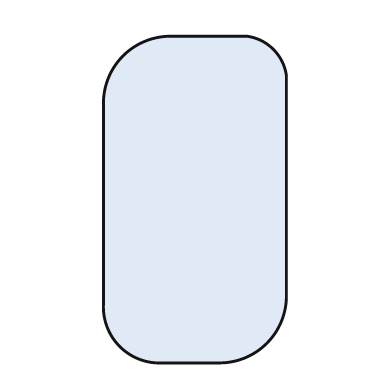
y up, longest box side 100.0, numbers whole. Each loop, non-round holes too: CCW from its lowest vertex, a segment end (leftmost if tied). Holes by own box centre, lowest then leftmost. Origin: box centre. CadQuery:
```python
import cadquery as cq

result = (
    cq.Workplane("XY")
    .moveTo(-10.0, -50.0)
    .lineTo(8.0, -50.0)
    .threePointArc((22.0, -44.0), (28.0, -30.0))
    .lineTo(28.0, 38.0)
    .threePointArc((24.0, 46.0), (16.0, 50.0))
    .lineTo(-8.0, 50.0)
    .threePointArc((-22.0, 44.0), (-28.0, 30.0))
    .lineTo(-28.0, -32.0)
    .threePointArc((-23.0, -45.0), (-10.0, -50.0))
    .close()
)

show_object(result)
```